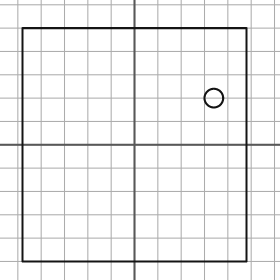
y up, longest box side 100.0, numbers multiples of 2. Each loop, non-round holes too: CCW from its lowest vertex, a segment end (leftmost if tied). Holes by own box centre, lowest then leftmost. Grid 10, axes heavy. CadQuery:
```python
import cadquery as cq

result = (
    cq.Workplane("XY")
    .moveTo(-48.0, -50.0)
    .lineTo(48.0, -50.0)
    .lineTo(48.0, 50.0)
    .lineTo(-48.0, 50.0)
    .close()
    .moveTo(34.0, 20.0)
    .circle(4.0)
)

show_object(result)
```